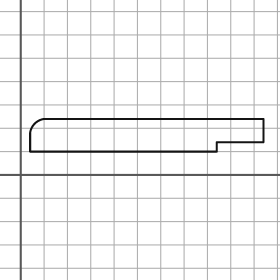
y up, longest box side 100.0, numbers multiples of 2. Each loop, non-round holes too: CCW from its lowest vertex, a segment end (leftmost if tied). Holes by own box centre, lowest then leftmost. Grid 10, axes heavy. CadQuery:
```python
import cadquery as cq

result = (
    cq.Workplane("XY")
    .moveTo(4.0, 10.0)
    .lineTo(84.0, 10.0)
    .lineTo(84.0, 14.0)
    .lineTo(104.0, 14.0)
    .lineTo(104.0, 24.0)
    .lineTo(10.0, 24.0)
    .threePointArc((6.0, 22.0), (4.0, 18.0))
    .close()
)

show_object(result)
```